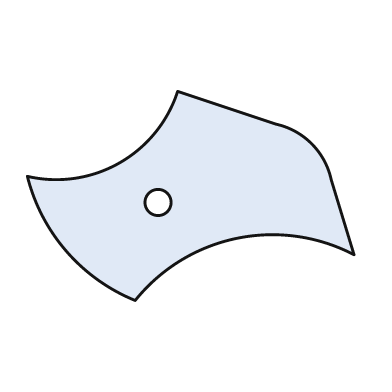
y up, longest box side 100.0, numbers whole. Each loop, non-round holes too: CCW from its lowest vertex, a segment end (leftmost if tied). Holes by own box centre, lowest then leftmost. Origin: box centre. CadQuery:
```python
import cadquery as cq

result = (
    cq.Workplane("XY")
    .moveTo(-17.0, -32.0)
    .threePointArc((14.0, -13.0), (50.0, -18.0))
    .lineTo(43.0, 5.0)
    .threePointArc((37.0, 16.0), (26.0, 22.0))
    .lineTo(-4.0, 32.0)
    .threePointArc((-22.0, 10.0), (-50.0, 6.0))
    .threePointArc((-38.0, -17.0), (-17.0, -32.0))
    .close()
    .moveTo(-10.0, -2.0)
    .circle(4.0)
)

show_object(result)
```